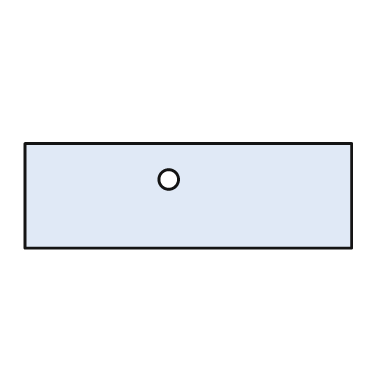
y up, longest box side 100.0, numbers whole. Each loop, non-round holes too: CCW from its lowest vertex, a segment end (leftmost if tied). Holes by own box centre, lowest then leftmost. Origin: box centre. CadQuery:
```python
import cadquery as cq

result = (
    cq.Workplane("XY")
    .moveTo(-50.0, -16.0)
    .lineTo(50.0, -16.0)
    .lineTo(50.0, 16.0)
    .lineTo(-50.0, 16.0)
    .close()
    .moveTo(-6.0, 5.0)
    .circle(3.0)
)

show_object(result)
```